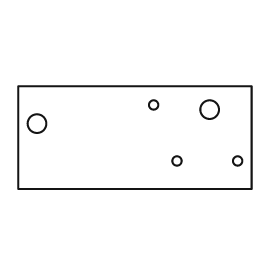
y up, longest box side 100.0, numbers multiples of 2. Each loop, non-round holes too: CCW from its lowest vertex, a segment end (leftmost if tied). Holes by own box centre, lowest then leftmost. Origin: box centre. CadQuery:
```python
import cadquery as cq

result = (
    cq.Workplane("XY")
    .moveTo(-50.0, -22.0)
    .lineTo(50.0, -22.0)
    .lineTo(50.0, 22.0)
    .lineTo(-50.0, 22.0)
    .close()
    .moveTo(18.0, -10.0)
    .circle(2.0)
    .moveTo(44.0, -10.0)
    .circle(2.0)
    .moveTo(-42.0, 6.0)
    .circle(4.0)
    .moveTo(32.0, 12.0)
    .circle(4.0)
    .moveTo(8.0, 14.0)
    .circle(2.0)
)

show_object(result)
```